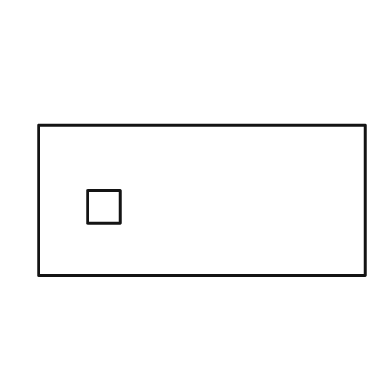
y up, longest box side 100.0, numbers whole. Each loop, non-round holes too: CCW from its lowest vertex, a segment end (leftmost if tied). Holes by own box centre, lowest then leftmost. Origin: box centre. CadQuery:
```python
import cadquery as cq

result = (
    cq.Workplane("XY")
    .moveTo(-50.0, -23.0)
    .lineTo(50.0, -23.0)
    .lineTo(50.0, 23.0)
    .lineTo(-50.0, 23.0)
    .close()
    .moveTo(-35.0, -7.0)
    .lineTo(-25.0, -7.0)
    .lineTo(-25.0, 3.0)
    .lineTo(-35.0, 3.0)
    .close()
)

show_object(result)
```